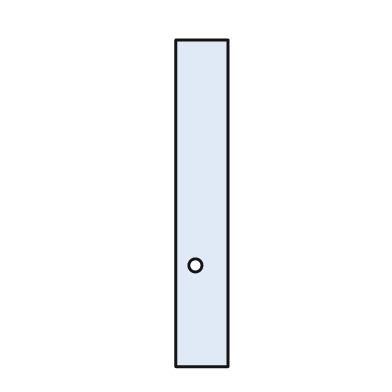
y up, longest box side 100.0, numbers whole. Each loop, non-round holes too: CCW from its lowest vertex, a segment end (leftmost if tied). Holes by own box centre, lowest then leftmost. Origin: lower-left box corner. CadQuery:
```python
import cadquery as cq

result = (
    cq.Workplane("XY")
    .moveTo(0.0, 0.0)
    .lineTo(16.0, 0.0)
    .lineTo(16.0, 100.0)
    .lineTo(0.0, 100.0)
    .close()
    .moveTo(6.0, 31.0)
    .circle(2.0)
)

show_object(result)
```